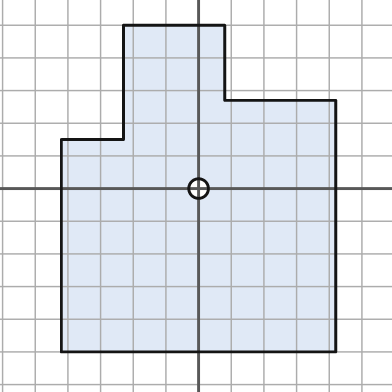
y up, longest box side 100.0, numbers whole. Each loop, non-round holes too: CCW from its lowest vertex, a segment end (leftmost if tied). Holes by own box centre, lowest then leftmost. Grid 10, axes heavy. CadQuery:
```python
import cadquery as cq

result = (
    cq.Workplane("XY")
    .moveTo(-42.0, -50.0)
    .lineTo(42.0, -50.0)
    .lineTo(42.0, 27.0)
    .lineTo(8.0, 27.0)
    .lineTo(8.0, 50.0)
    .lineTo(-23.0, 50.0)
    .lineTo(-23.0, 15.0)
    .lineTo(-42.0, 15.0)
    .close()
    .moveTo(0.0, 0.0)
    .circle(3.0)
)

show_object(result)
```